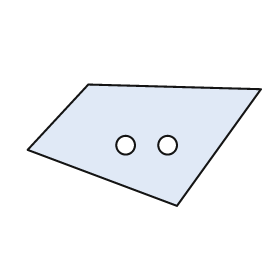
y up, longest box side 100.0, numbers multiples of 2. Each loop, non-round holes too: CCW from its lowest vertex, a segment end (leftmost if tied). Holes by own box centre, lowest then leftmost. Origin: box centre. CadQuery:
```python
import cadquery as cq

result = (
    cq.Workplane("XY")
    .moveTo(14.0, -26.0)
    .lineTo(50.0, 24.0)
    .lineTo(-24.0, 26.0)
    .lineTo(-50.0, -2.0)
    .close()
    .moveTo(-8.0, 0.0)
    .circle(4.0)
    .moveTo(10.0, 0.0)
    .circle(4.0)
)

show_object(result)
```